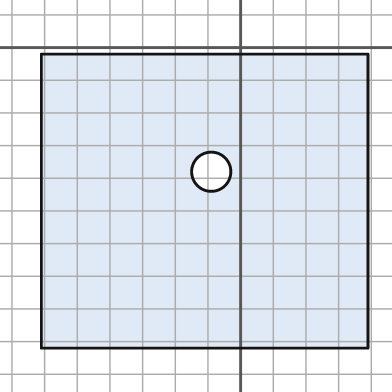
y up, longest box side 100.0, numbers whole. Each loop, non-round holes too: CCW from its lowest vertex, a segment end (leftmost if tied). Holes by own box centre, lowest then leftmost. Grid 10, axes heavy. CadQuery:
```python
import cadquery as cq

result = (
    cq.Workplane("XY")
    .moveTo(-61.0, -92.0)
    .lineTo(39.0, -92.0)
    .lineTo(39.0, -2.0)
    .lineTo(-61.0, -2.0)
    .close()
    .moveTo(-9.0, -38.0)
    .circle(6.0)
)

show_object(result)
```